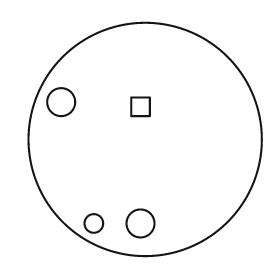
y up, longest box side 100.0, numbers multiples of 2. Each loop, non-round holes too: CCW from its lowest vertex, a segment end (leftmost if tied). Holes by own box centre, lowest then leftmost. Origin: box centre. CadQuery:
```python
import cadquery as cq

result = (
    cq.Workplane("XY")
    .moveTo(0.0, 0.0)
    .circle(50.0)
    .moveTo(-22.0, -36.0)
    .circle(4.0)
    .moveTo(-2.0, -36.0)
    .circle(6.0)
    .moveTo(-6.0, 10.0)
    .lineTo(2.0, 10.0)
    .lineTo(2.0, 18.0)
    .lineTo(-6.0, 18.0)
    .close()
    .moveTo(-36.0, 16.0)
    .circle(6.0)
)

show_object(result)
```